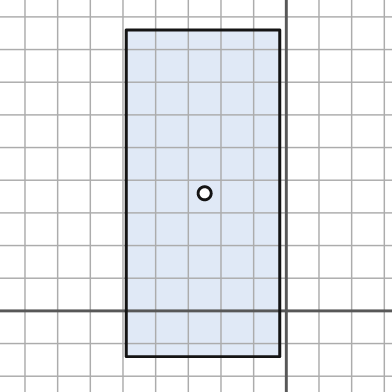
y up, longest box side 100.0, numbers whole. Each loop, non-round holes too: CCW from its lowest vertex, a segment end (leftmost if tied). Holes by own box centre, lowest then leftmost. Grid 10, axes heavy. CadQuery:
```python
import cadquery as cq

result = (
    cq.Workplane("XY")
    .moveTo(-49.0, -14.0)
    .lineTo(-2.0, -14.0)
    .lineTo(-2.0, 86.0)
    .lineTo(-49.0, 86.0)
    .close()
    .moveTo(-25.0, 36.0)
    .circle(2.0)
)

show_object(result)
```